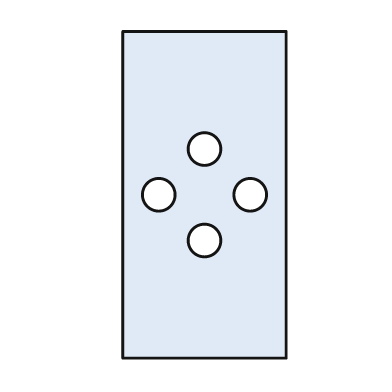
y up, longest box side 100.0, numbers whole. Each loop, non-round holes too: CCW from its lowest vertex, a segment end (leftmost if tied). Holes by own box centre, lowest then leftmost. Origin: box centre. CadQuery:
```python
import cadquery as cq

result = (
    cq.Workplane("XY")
    .moveTo(-25.0, -50.0)
    .lineTo(25.0, -50.0)
    .lineTo(25.0, 50.0)
    .lineTo(-25.0, 50.0)
    .close()
    .moveTo(0.0, -14.0)
    .circle(5.0)
    .moveTo(-14.0, 0.0)
    .circle(5.0)
    .moveTo(14.0, 0.0)
    .circle(5.0)
    .moveTo(0.0, 14.0)
    .circle(5.0)
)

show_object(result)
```